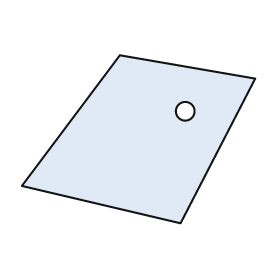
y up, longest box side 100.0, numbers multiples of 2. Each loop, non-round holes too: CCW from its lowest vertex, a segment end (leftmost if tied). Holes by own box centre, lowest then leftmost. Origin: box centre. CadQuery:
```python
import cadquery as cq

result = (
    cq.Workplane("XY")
    .moveTo(18.0, -36.0)
    .lineTo(50.0, 26.0)
    .lineTo(-8.0, 36.0)
    .lineTo(-50.0, -20.0)
    .close()
    .moveTo(20.0, 12.0)
    .circle(4.0)
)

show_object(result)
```